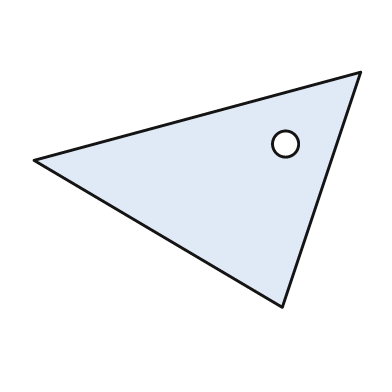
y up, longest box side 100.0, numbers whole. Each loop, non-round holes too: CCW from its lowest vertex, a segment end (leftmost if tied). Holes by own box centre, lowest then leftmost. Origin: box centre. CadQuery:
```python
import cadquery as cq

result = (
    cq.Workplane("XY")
    .moveTo(26.0, -36.0)
    .lineTo(50.0, 36.0)
    .lineTo(-50.0, 9.0)
    .close()
    .moveTo(27.0, 14.0)
    .circle(4.0)
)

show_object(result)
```